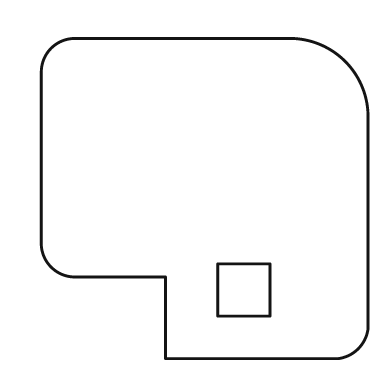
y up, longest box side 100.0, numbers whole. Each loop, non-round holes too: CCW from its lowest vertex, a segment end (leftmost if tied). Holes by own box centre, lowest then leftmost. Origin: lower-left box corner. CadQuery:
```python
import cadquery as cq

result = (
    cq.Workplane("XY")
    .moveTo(38.0, 0.0)
    .lineTo(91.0, 0.0)
    .threePointArc((97.0, 3.0), (100.0, 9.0))
    .lineTo(100.0, 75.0)
    .threePointArc((93.0, 91.0), (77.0, 98.0))
    .lineTo(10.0, 98.0)
    .threePointArc((3.0, 95.0), (0.0, 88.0))
    .lineTo(0.0, 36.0)
    .threePointArc((3.0, 28.0), (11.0, 25.0))
    .lineTo(38.0, 25.0)
    .close()
    .moveTo(54.0, 13.0)
    .lineTo(70.0, 13.0)
    .lineTo(70.0, 29.0)
    .lineTo(54.0, 29.0)
    .close()
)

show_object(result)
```